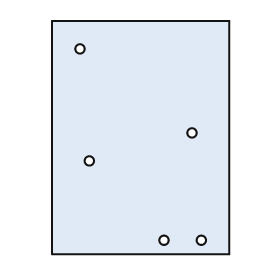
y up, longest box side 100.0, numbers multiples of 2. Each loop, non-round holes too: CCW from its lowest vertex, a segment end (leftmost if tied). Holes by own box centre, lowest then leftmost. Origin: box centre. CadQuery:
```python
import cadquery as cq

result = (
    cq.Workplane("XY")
    .moveTo(-38.0, -50.0)
    .lineTo(38.0, -50.0)
    .lineTo(38.0, 50.0)
    .lineTo(-38.0, 50.0)
    .close()
    .moveTo(10.0, -44.0)
    .circle(2.0)
    .moveTo(26.0, -44.0)
    .circle(2.0)
    .moveTo(-22.0, -10.0)
    .circle(2.0)
    .moveTo(22.0, 2.0)
    .circle(2.0)
    .moveTo(-26.0, 38.0)
    .circle(2.0)
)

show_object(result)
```